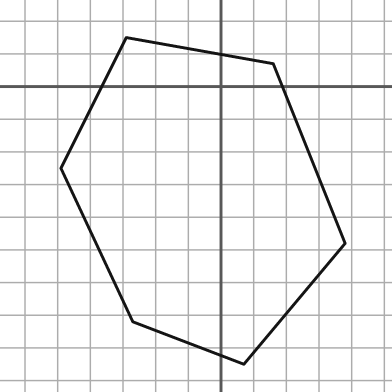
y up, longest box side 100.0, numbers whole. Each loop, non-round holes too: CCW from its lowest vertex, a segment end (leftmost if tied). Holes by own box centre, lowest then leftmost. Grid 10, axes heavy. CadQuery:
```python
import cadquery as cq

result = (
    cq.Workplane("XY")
    .moveTo(7.0, -85.0)
    .lineTo(38.0, -48.0)
    .lineTo(16.0, 7.0)
    .lineTo(-29.0, 15.0)
    .lineTo(-49.0, -25.0)
    .lineTo(-27.0, -72.0)
    .close()
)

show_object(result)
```